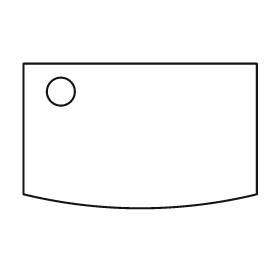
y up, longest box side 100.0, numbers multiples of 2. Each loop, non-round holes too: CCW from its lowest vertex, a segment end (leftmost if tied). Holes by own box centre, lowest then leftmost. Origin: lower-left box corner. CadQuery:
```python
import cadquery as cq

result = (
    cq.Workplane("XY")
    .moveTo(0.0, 6.0)
    .threePointArc((50.0, 0.0), (100.0, 6.0))
    .lineTo(100.0, 62.0)
    .lineTo(0.0, 62.0)
    .close()
    .moveTo(16.0, 50.0)
    .circle(6.0)
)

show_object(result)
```